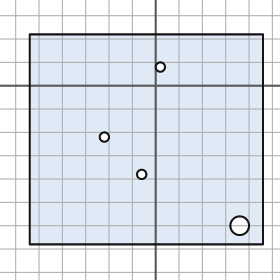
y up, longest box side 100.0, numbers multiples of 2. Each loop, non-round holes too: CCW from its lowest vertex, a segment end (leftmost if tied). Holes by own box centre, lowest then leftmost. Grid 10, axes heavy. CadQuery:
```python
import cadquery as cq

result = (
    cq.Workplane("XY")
    .moveTo(-54.0, -68.0)
    .lineTo(46.0, -68.0)
    .lineTo(46.0, 22.0)
    .lineTo(-54.0, 22.0)
    .close()
    .moveTo(36.0, -60.0)
    .circle(4.0)
    .moveTo(-6.0, -38.0)
    .circle(2.0)
    .moveTo(-22.0, -22.0)
    .circle(2.0)
    .moveTo(2.0, 8.0)
    .circle(2.0)
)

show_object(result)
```